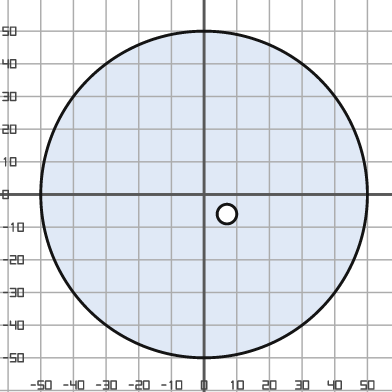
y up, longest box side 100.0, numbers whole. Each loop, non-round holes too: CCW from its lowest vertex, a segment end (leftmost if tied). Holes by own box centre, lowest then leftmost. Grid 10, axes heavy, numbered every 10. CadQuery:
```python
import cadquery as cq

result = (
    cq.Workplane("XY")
    .moveTo(0.0, 0.0)
    .circle(50.0)
    .moveTo(7.0, -6.0)
    .circle(3.0)
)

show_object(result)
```